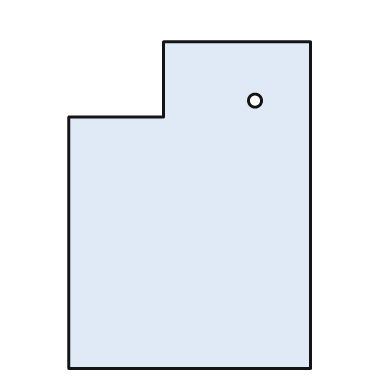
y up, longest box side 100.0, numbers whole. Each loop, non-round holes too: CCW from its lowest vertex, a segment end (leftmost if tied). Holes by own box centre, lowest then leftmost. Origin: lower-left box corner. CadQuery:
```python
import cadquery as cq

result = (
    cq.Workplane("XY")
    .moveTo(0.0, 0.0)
    .lineTo(74.0, 0.0)
    .lineTo(74.0, 100.0)
    .lineTo(29.0, 100.0)
    .lineTo(29.0, 77.0)
    .lineTo(0.0, 77.0)
    .close()
    .moveTo(57.0, 82.0)
    .circle(2.0)
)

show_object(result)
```